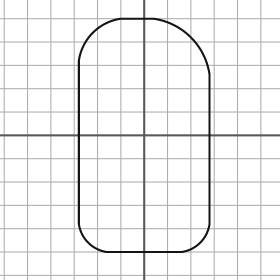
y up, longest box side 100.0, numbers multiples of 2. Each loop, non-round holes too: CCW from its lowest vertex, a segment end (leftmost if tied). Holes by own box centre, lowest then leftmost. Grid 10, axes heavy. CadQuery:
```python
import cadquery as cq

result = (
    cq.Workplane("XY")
    .moveTo(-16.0, -50.0)
    .lineTo(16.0, -50.0)
    .threePointArc((24.0, -46.0), (28.0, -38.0))
    .lineTo(28.0, 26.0)
    .threePointArc((20.0, 42.0), (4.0, 50.0))
    .lineTo(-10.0, 50.0)
    .threePointArc((-22.0, 44.0), (-28.0, 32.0))
    .lineTo(-28.0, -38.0)
    .threePointArc((-24.0, -46.0), (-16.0, -50.0))
    .close()
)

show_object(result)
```